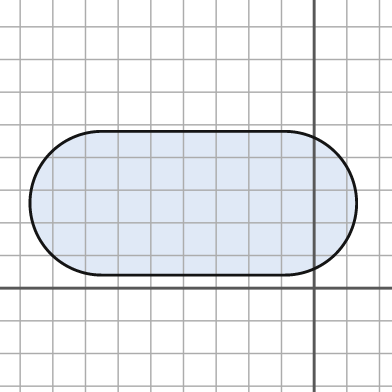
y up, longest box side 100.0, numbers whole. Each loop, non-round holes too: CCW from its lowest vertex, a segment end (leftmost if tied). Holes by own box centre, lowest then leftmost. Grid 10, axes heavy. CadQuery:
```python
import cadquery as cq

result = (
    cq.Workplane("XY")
    .moveTo(-65.0, 4.0)
    .lineTo(-9.0, 4.0)
    .threePointArc((13.0, 26.0), (-9.0, 48.0))
    .lineTo(-65.0, 48.0)
    .threePointArc((-87.0, 26.0), (-65.0, 4.0))
    .close()
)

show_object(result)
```